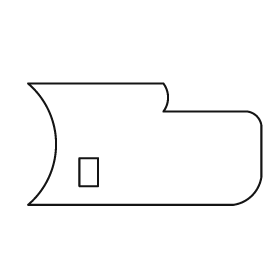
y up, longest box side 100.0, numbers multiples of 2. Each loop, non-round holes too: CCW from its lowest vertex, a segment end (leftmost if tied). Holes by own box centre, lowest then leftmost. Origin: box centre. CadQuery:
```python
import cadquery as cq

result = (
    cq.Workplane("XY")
    .moveTo(-50.0, -26.0)
    .lineTo(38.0, -26.0)
    .threePointArc((46.0, -22.0), (50.0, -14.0))
    .lineTo(50.0, 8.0)
    .threePointArc((48.0, 12.0), (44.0, 14.0))
    .lineTo(8.0, 14.0)
    .threePointArc((10.0, 20.0), (8.0, 26.0))
    .lineTo(-50.0, 26.0)
    .threePointArc((-38.0, 0.0), (-50.0, -26.0))
    .close()
    .moveTo(-28.0, -18.0)
    .lineTo(-20.0, -18.0)
    .lineTo(-20.0, -6.0)
    .lineTo(-28.0, -6.0)
    .close()
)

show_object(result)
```